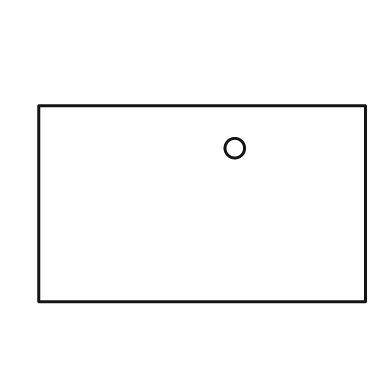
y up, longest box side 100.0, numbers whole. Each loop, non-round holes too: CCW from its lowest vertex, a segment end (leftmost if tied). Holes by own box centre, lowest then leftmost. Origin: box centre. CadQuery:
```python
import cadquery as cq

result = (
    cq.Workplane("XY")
    .moveTo(-50.0, -30.0)
    .lineTo(50.0, -30.0)
    .lineTo(50.0, 30.0)
    .lineTo(-50.0, 30.0)
    .close()
    .moveTo(10.0, 17.0)
    .circle(3.0)
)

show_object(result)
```